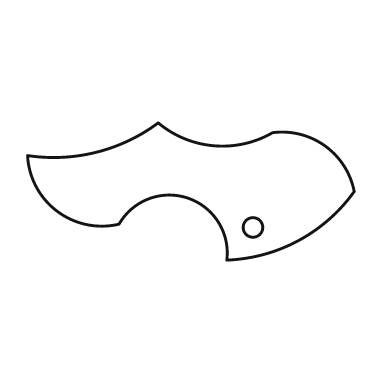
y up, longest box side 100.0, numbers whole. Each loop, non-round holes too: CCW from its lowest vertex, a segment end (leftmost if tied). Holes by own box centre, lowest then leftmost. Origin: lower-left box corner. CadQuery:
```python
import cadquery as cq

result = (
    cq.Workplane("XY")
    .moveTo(61.0, 0.0)
    .threePointArc((83.0, 6.0), (100.0, 21.0))
    .threePointArc((91.0, 35.0), (75.0, 39.0))
    .threePointArc((57.0, 35.0), (40.0, 42.0))
    .threePointArc((21.0, 33.0), (0.0, 32.0))
    .threePointArc((9.0, 15.0), (28.0, 11.0))
    .threePointArc((49.0, 19.0), (61.0, 0.0))
    .close()
    .moveTo(69.0, 10.0)
    .circle(3.0)
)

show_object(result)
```